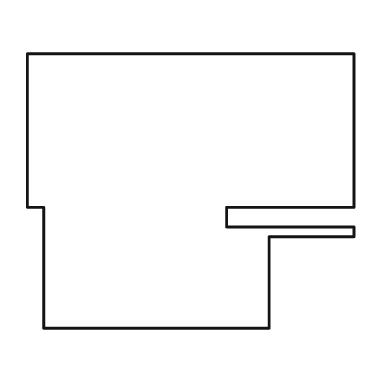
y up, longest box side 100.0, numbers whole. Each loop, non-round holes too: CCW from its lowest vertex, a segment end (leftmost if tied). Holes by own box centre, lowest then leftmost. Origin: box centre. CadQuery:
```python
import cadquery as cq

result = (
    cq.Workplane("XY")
    .moveTo(-45.0, -42.0)
    .lineTo(24.0, -42.0)
    .lineTo(24.0, -14.0)
    .lineTo(50.0, -14.0)
    .lineTo(50.0, -11.0)
    .lineTo(11.0, -11.0)
    .lineTo(11.0, -5.0)
    .lineTo(50.0, -5.0)
    .lineTo(50.0, 42.0)
    .lineTo(-50.0, 42.0)
    .lineTo(-50.0, -5.0)
    .lineTo(-45.0, -5.0)
    .close()
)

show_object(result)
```